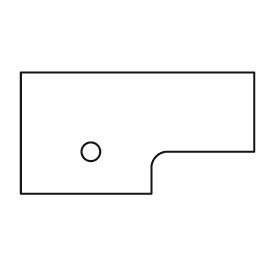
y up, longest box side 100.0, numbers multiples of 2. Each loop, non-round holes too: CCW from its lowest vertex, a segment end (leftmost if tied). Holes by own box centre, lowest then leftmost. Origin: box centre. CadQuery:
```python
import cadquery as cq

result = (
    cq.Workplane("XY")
    .moveTo(-50.0, -26.0)
    .lineTo(6.0, -26.0)
    .lineTo(6.0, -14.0)
    .threePointArc((8.0, -10.0), (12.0, -8.0))
    .lineTo(50.0, -8.0)
    .lineTo(50.0, 26.0)
    .lineTo(-50.0, 26.0)
    .close()
    .moveTo(-20.0, -8.0)
    .circle(4.0)
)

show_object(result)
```